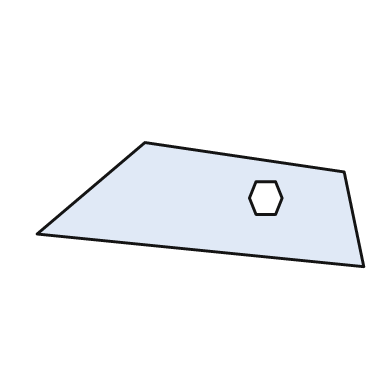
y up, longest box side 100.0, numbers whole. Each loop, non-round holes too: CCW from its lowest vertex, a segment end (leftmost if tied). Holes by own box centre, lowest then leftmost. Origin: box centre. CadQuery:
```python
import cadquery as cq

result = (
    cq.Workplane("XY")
    .moveTo(50.0, -19.0)
    .lineTo(44.0, 10.0)
    .lineTo(-17.0, 19.0)
    .lineTo(-50.0, -9.0)
    .close()
    .moveTo(17.0, -3.0)
    .lineTo(23.0, -3.0)
    .lineTo(25.0, 2.0)
    .lineTo(23.0, 7.0)
    .lineTo(17.0, 7.0)
    .lineTo(15.0, 2.0)
    .close()
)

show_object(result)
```